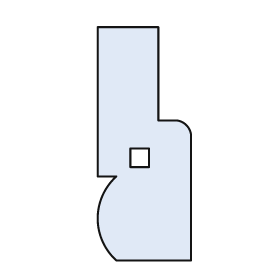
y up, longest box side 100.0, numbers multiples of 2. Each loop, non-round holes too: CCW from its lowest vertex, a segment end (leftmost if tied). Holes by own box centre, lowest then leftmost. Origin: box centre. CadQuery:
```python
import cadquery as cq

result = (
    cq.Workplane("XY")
    .moveTo(-12.0, -50.0)
    .lineTo(20.0, -50.0)
    .lineTo(20.0, 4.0)
    .threePointArc((18.0, 8.0), (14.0, 10.0))
    .lineTo(6.0, 10.0)
    .lineTo(6.0, 50.0)
    .lineTo(-20.0, 50.0)
    .lineTo(-20.0, -14.0)
    .lineTo(-12.0, -14.0)
    .threePointArc((-20.0, -32.0), (-12.0, -50.0))
    .close()
    .moveTo(-6.0, -10.0)
    .lineTo(2.0, -10.0)
    .lineTo(2.0, -2.0)
    .lineTo(-6.0, -2.0)
    .close()
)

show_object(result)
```